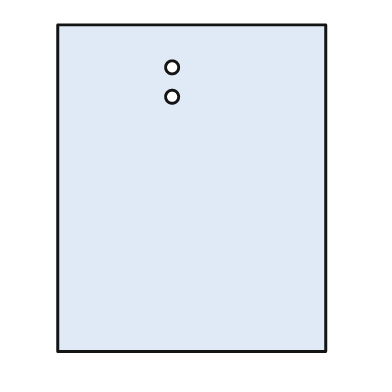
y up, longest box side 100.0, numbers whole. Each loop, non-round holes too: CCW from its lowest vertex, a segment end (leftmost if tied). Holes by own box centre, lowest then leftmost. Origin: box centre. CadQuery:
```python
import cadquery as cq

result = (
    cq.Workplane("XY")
    .moveTo(-41.0, -50.0)
    .lineTo(41.0, -50.0)
    .lineTo(41.0, 50.0)
    .lineTo(-41.0, 50.0)
    .close()
    .moveTo(-6.0, 28.0)
    .circle(2.0)
    .moveTo(-6.0, 37.0)
    .circle(2.0)
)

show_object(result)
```